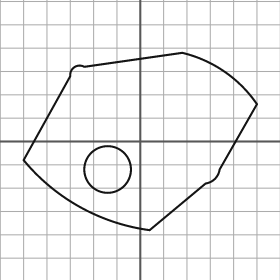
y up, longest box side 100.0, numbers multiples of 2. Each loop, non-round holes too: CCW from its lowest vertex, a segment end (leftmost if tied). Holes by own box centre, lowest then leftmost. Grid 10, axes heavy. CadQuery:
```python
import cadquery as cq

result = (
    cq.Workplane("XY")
    .moveTo(4.0, -38.0)
    .lineTo(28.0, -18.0)
    .threePointArc((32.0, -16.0), (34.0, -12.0))
    .lineTo(50.0, 16.0)
    .threePointArc((36.0, 30.0), (18.0, 38.0))
    .lineTo(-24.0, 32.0)
    .threePointArc((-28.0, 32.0), (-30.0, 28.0))
    .lineTo(-50.0, -8.0)
    .threePointArc((-26.0, -28.0), (4.0, -38.0))
    .close()
    .moveTo(-14.0, -12.0)
    .circle(10.0)
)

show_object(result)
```